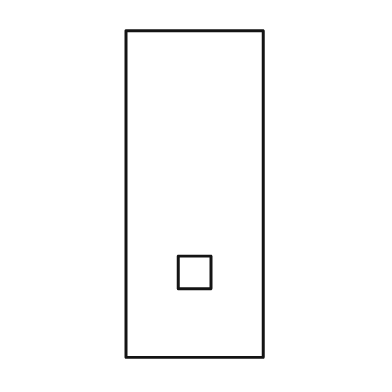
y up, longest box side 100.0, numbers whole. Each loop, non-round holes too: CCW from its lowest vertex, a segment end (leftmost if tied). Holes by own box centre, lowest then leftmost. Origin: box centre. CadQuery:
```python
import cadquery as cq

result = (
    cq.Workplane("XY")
    .moveTo(-21.0, -50.0)
    .lineTo(21.0, -50.0)
    .lineTo(21.0, 50.0)
    .lineTo(-21.0, 50.0)
    .close()
    .moveTo(-5.0, -29.0)
    .lineTo(5.0, -29.0)
    .lineTo(5.0, -19.0)
    .lineTo(-5.0, -19.0)
    .close()
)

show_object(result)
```